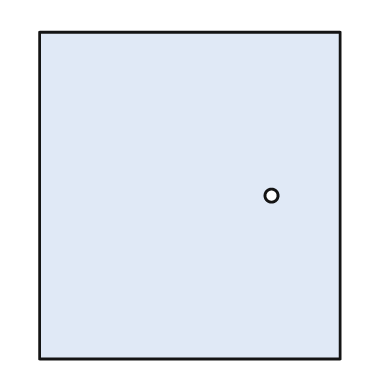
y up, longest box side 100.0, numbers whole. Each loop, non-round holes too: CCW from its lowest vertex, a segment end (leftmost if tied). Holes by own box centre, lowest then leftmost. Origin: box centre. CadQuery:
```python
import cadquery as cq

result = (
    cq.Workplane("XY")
    .moveTo(-46.0, -50.0)
    .lineTo(46.0, -50.0)
    .lineTo(46.0, 50.0)
    .lineTo(-46.0, 50.0)
    .close()
    .moveTo(25.0, 0.0)
    .circle(2.0)
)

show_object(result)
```